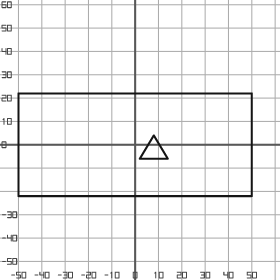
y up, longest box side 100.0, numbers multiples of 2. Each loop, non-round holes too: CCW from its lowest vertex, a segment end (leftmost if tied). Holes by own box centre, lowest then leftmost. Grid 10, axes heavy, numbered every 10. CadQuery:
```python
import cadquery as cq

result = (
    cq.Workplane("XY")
    .moveTo(-50.0, -22.0)
    .lineTo(50.0, -22.0)
    .lineTo(50.0, 22.0)
    .lineTo(-50.0, 22.0)
    .close()
    .moveTo(2.0, -6.0)
    .lineTo(14.0, -6.0)
    .lineTo(8.0, 4.0)
    .close()
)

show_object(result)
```